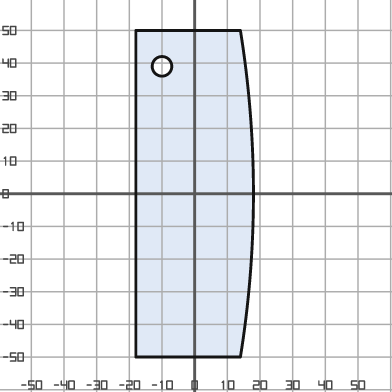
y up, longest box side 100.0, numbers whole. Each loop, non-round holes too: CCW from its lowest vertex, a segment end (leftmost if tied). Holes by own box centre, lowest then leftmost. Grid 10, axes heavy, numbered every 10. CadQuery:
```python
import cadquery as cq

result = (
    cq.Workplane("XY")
    .moveTo(-18.0, -50.0)
    .lineTo(14.0, -50.0)
    .threePointArc((18.0, 0.0), (14.0, 50.0))
    .lineTo(-18.0, 50.0)
    .close()
    .moveTo(-10.0, 39.0)
    .circle(3.0)
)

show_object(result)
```